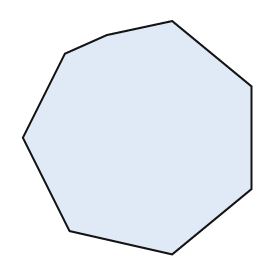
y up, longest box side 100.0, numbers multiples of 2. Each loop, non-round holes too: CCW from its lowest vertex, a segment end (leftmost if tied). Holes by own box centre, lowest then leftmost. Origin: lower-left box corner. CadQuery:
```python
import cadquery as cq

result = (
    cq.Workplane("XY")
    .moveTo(64.0, 0.0)
    .lineTo(98.0, 28.0)
    .lineTo(98.0, 72.0)
    .lineTo(64.0, 100.0)
    .lineTo(36.0, 94.0)
    .lineTo(18.0, 86.0)
    .lineTo(0.0, 50.0)
    .lineTo(20.0, 10.0)
    .close()
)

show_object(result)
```